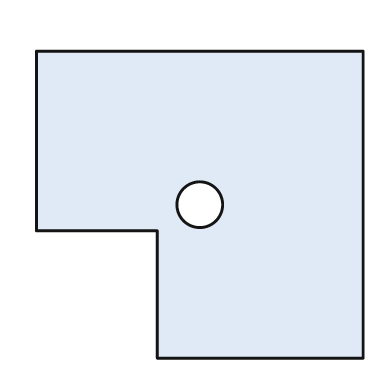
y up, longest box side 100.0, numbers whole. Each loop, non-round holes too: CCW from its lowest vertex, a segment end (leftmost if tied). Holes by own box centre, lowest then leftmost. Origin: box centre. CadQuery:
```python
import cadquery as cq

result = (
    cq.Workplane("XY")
    .moveTo(-13.0, -47.0)
    .lineTo(50.0, -47.0)
    .lineTo(50.0, 47.0)
    .lineTo(-50.0, 47.0)
    .lineTo(-50.0, -8.0)
    .lineTo(-13.0, -8.0)
    .close()
    .moveTo(0.0, 0.0)
    .circle(7.0)
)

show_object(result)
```